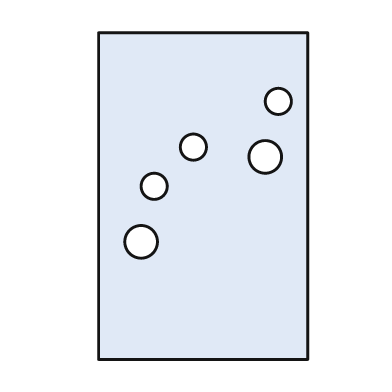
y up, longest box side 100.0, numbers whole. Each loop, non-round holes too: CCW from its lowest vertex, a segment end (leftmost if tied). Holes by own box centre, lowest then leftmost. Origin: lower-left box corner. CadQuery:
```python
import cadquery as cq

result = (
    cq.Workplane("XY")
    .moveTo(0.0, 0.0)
    .lineTo(64.0, 0.0)
    .lineTo(64.0, 100.0)
    .lineTo(0.0, 100.0)
    .close()
    .moveTo(13.0, 36.0)
    .circle(5.0)
    .moveTo(17.0, 53.0)
    .circle(4.0)
    .moveTo(51.0, 62.0)
    .circle(5.0)
    .moveTo(29.0, 65.0)
    .circle(4.0)
    .moveTo(55.0, 79.0)
    .circle(4.0)
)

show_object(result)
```